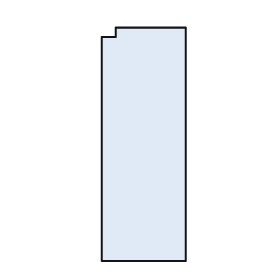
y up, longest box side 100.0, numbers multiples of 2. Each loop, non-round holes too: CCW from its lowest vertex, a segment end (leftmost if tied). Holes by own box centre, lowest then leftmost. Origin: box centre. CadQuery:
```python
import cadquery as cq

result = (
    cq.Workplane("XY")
    .moveTo(-18.0, -50.0)
    .lineTo(18.0, -50.0)
    .lineTo(18.0, 50.0)
    .lineTo(-12.0, 50.0)
    .lineTo(-12.0, 46.0)
    .lineTo(-18.0, 46.0)
    .close()
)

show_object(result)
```